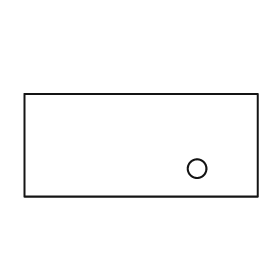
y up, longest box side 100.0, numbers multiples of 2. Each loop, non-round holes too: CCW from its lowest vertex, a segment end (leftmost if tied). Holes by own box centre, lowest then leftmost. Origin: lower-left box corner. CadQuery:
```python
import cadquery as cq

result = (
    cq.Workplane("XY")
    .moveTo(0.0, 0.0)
    .lineTo(100.0, 0.0)
    .lineTo(100.0, 44.0)
    .lineTo(0.0, 44.0)
    .close()
    .moveTo(74.0, 12.0)
    .circle(4.0)
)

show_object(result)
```